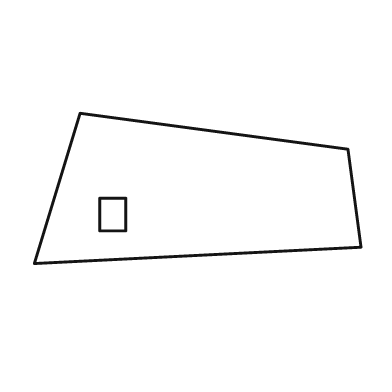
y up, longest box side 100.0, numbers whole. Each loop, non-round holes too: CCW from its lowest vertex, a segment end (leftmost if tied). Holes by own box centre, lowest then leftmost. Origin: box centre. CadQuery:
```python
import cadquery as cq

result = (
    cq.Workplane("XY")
    .moveTo(-50.0, -23.0)
    .lineTo(50.0, -18.0)
    .lineTo(46.0, 12.0)
    .lineTo(-36.0, 23.0)
    .close()
    .moveTo(-30.0, -13.0)
    .lineTo(-22.0, -13.0)
    .lineTo(-22.0, -3.0)
    .lineTo(-30.0, -3.0)
    .close()
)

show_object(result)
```